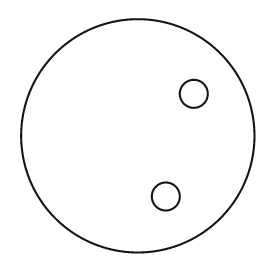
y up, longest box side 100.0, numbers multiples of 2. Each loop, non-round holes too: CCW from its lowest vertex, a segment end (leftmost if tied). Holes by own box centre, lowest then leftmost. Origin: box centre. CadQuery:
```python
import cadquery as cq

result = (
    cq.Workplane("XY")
    .moveTo(0.0, 0.0)
    .circle(50.0)
    .moveTo(12.0, -26.0)
    .circle(6.0)
    .moveTo(24.0, 18.0)
    .circle(6.0)
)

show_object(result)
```